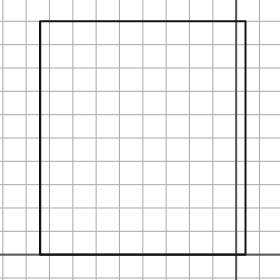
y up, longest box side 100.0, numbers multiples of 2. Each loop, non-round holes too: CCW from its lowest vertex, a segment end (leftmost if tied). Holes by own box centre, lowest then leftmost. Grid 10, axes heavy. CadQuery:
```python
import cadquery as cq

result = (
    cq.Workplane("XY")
    .moveTo(-84.0, 0.0)
    .lineTo(4.0, 0.0)
    .lineTo(4.0, 100.0)
    .lineTo(-84.0, 100.0)
    .close()
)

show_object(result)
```